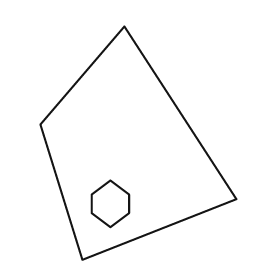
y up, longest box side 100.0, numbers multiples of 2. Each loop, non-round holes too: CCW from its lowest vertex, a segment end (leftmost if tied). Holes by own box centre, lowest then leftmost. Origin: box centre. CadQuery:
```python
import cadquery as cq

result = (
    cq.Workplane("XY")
    .moveTo(-24.0, -50.0)
    .lineTo(42.0, -24.0)
    .lineTo(-6.0, 50.0)
    .lineTo(-42.0, 8.0)
    .close()
    .moveTo(-12.0, -36.0)
    .lineTo(-4.0, -30.0)
    .lineTo(-4.0, -22.0)
    .lineTo(-12.0, -16.0)
    .lineTo(-20.0, -22.0)
    .lineTo(-20.0, -30.0)
    .close()
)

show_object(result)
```